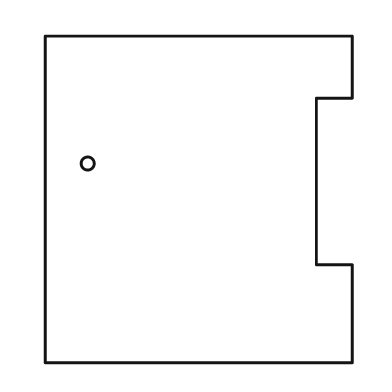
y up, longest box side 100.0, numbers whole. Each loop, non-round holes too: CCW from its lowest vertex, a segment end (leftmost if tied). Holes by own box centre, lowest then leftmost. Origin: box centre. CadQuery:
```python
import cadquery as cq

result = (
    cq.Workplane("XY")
    .moveTo(-47.0, -50.0)
    .lineTo(47.0, -50.0)
    .lineTo(47.0, -20.0)
    .lineTo(36.0, -20.0)
    .lineTo(36.0, 31.0)
    .lineTo(47.0, 31.0)
    .lineTo(47.0, 50.0)
    .lineTo(-47.0, 50.0)
    .close()
    .moveTo(-34.0, 11.0)
    .circle(2.0)
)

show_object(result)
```